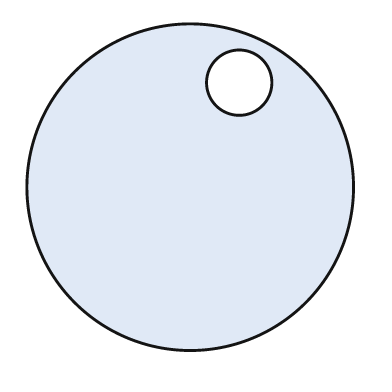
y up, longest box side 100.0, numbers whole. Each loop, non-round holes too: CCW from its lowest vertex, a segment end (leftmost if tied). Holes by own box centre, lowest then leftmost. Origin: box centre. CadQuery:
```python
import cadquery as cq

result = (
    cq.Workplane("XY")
    .moveTo(0.0, 0.0)
    .circle(50.0)
    .moveTo(15.0, 32.0)
    .circle(10.0)
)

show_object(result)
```